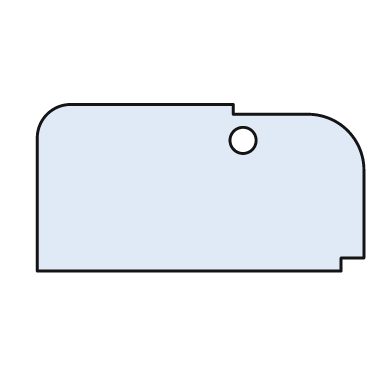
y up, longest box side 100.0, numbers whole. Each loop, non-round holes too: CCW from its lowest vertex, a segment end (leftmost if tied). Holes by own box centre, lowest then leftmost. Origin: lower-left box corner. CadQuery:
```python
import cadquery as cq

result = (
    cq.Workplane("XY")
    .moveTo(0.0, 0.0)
    .lineTo(93.0, 0.0)
    .lineTo(93.0, 4.0)
    .lineTo(100.0, 4.0)
    .lineTo(100.0, 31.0)
    .threePointArc((95.0, 43.0), (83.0, 48.0))
    .lineTo(60.0, 48.0)
    .lineTo(60.0, 51.0)
    .lineTo(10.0, 51.0)
    .threePointArc((3.0, 48.0), (0.0, 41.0))
    .close()
    .moveTo(63.0, 40.0)
    .circle(4.0)
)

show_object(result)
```